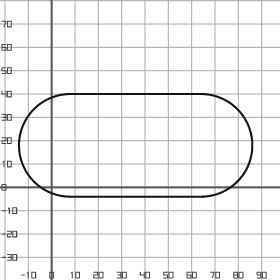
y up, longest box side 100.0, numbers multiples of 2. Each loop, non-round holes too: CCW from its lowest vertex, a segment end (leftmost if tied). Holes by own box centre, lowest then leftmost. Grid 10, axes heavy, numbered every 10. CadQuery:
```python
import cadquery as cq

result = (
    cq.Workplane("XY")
    .moveTo(8.0, -4.0)
    .lineTo(64.0, -4.0)
    .threePointArc((86.0, 18.0), (64.0, 40.0))
    .lineTo(8.0, 40.0)
    .threePointArc((-14.0, 18.0), (8.0, -4.0))
    .close()
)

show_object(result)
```